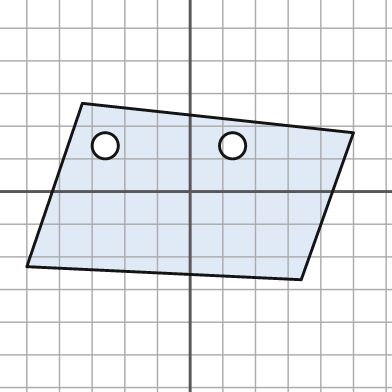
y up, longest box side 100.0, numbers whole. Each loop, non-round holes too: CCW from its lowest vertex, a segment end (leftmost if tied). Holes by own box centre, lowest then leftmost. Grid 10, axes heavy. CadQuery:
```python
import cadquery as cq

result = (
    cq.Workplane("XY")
    .moveTo(34.0, -27.0)
    .lineTo(50.0, 18.0)
    .lineTo(-33.0, 27.0)
    .lineTo(-50.0, -23.0)
    .close()
    .moveTo(-26.0, 14.0)
    .circle(4.0)
    .moveTo(13.0, 14.0)
    .circle(4.0)
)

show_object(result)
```